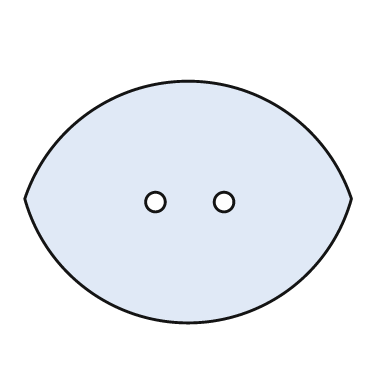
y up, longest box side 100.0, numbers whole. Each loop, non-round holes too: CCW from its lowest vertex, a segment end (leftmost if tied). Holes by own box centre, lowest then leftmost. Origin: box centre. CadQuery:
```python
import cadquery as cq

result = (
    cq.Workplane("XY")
    .moveTo(-50.0, 1.0)
    .threePointArc((0.0, -37.0), (50.0, 1.0))
    .threePointArc((0.0, 37.0), (-50.0, 1.0))
    .close()
    .moveTo(-10.0, 0.0)
    .circle(3.0)
    .moveTo(11.0, 0.0)
    .circle(3.0)
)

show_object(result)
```